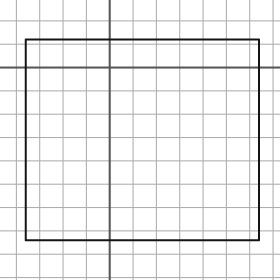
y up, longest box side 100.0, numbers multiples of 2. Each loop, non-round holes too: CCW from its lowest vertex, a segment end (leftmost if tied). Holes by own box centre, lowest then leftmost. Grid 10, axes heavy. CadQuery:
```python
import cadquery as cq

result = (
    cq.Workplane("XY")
    .moveTo(-36.0, -74.0)
    .lineTo(64.0, -74.0)
    .lineTo(64.0, 12.0)
    .lineTo(-36.0, 12.0)
    .close()
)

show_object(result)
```